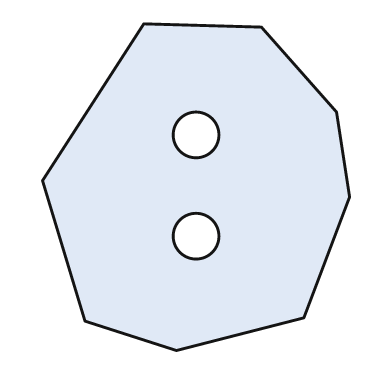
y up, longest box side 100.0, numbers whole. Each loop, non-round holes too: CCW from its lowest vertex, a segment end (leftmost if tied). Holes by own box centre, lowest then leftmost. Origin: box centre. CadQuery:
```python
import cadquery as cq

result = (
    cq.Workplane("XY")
    .moveTo(-6.0, -50.0)
    .lineTo(33.0, -40.0)
    .lineTo(47.0, -3.0)
    .lineTo(43.0, 23.0)
    .lineTo(20.0, 49.0)
    .lineTo(-16.0, 50.0)
    .lineTo(-47.0, 2.0)
    .lineTo(-34.0, -41.0)
    .close()
    .moveTo(0.0, -15.0)
    .circle(7.0)
    .moveTo(0.0, 16.0)
    .circle(7.0)
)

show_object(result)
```